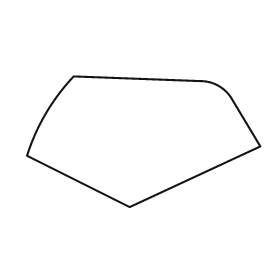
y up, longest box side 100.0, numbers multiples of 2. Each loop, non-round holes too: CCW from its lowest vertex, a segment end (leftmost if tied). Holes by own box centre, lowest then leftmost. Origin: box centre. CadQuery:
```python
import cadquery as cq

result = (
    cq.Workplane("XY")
    .moveTo(-6.0, -28.0)
    .lineTo(50.0, -2.0)
    .lineTo(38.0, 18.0)
    .threePointArc((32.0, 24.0), (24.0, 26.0))
    .lineTo(-30.0, 28.0)
    .threePointArc((-42.0, 12.0), (-50.0, -6.0))
    .close()
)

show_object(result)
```